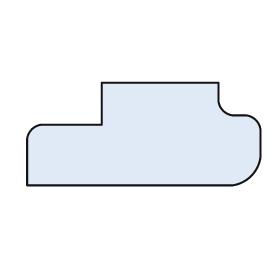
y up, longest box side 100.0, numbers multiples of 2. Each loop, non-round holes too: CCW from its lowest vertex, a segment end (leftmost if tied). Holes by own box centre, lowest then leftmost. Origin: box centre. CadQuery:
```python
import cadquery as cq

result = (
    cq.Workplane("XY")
    .moveTo(-50.0, -22.0)
    .lineTo(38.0, -22.0)
    .threePointArc((46.0, -18.0), (50.0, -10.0))
    .lineTo(50.0, 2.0)
    .threePointArc((48.0, 6.0), (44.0, 8.0))
    .lineTo(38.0, 8.0)
    .threePointArc((34.0, 10.0), (32.0, 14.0))
    .lineTo(32.0, 22.0)
    .lineTo(-18.0, 22.0)
    .lineTo(-18.0, 4.0)
    .lineTo(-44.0, 4.0)
    .threePointArc((-48.0, 2.0), (-50.0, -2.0))
    .close()
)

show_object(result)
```